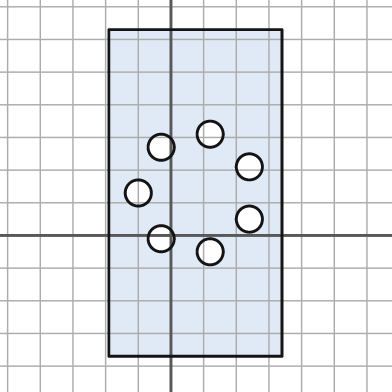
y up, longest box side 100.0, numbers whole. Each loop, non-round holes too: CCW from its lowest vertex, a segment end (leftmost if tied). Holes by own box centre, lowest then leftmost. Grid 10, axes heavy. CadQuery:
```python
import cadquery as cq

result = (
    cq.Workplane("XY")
    .moveTo(-19.0, -37.0)
    .lineTo(34.0, -37.0)
    .lineTo(34.0, 63.0)
    .lineTo(-19.0, 63.0)
    .close()
    .moveTo(12.0, -5.0)
    .circle(4.0)
    .moveTo(-3.0, -1.0)
    .circle(4.0)
    .moveTo(24.0, 5.0)
    .circle(4.0)
    .moveTo(-10.0, 13.0)
    .circle(4.0)
    .moveTo(24.0, 21.0)
    .circle(4.0)
    .moveTo(-3.0, 27.0)
    .circle(4.0)
    .moveTo(12.0, 31.0)
    .circle(4.0)
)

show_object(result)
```